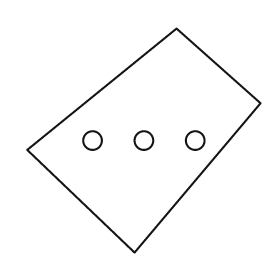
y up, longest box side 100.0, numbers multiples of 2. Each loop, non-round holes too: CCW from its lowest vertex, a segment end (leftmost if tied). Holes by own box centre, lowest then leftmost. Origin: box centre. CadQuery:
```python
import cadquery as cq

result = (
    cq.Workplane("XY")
    .moveTo(-4.0, -48.0)
    .lineTo(50.0, 16.0)
    .lineTo(14.0, 48.0)
    .lineTo(-50.0, -4.0)
    .close()
    .moveTo(-22.0, 0.0)
    .circle(4.0)
    .moveTo(0.0, 0.0)
    .circle(4.0)
    .moveTo(22.0, 0.0)
    .circle(4.0)
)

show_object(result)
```